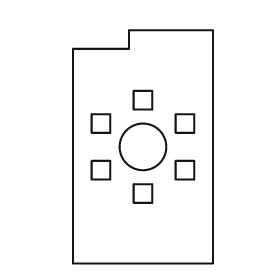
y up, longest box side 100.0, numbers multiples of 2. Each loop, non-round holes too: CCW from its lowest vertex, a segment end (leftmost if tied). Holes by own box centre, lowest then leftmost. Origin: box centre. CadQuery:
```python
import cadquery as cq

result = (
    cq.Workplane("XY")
    .moveTo(-30.0, -50.0)
    .lineTo(30.0, -50.0)
    .lineTo(30.0, 50.0)
    .lineTo(-6.0, 50.0)
    .lineTo(-6.0, 42.0)
    .lineTo(-30.0, 42.0)
    .close()
    .moveTo(-4.0, -24.0)
    .lineTo(4.0, -24.0)
    .lineTo(4.0, -16.0)
    .lineTo(-4.0, -16.0)
    .close()
    .moveTo(-22.0, -14.0)
    .lineTo(-14.0, -14.0)
    .lineTo(-14.0, -6.0)
    .lineTo(-22.0, -6.0)
    .close()
    .moveTo(14.0, -14.0)
    .lineTo(22.0, -14.0)
    .lineTo(22.0, -6.0)
    .lineTo(14.0, -6.0)
    .close()
    .moveTo(0.0, 0.0)
    .circle(10.0)
    .moveTo(-22.0, 6.0)
    .lineTo(-14.0, 6.0)
    .lineTo(-14.0, 14.0)
    .lineTo(-22.0, 14.0)
    .close()
    .moveTo(14.0, 6.0)
    .lineTo(22.0, 6.0)
    .lineTo(22.0, 14.0)
    .lineTo(14.0, 14.0)
    .close()
    .moveTo(-4.0, 16.0)
    .lineTo(4.0, 16.0)
    .lineTo(4.0, 24.0)
    .lineTo(-4.0, 24.0)
    .close()
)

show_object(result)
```